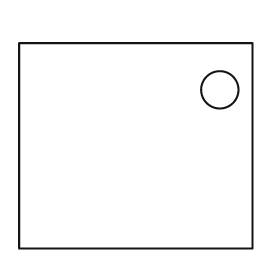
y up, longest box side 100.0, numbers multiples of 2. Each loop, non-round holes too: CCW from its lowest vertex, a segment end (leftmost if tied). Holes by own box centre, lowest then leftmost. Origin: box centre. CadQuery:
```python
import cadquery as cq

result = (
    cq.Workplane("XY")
    .moveTo(-50.0, -44.0)
    .lineTo(50.0, -44.0)
    .lineTo(50.0, 44.0)
    .lineTo(-50.0, 44.0)
    .close()
    .moveTo(36.0, 24.0)
    .circle(8.0)
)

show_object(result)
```